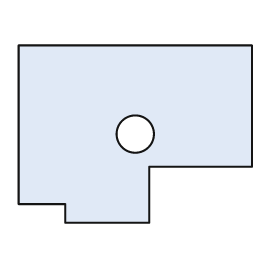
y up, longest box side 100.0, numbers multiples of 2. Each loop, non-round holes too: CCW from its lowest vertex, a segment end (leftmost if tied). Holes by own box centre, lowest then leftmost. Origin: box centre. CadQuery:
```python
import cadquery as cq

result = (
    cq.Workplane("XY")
    .moveTo(-30.0, -38.0)
    .lineTo(6.0, -38.0)
    .lineTo(6.0, -14.0)
    .lineTo(50.0, -14.0)
    .lineTo(50.0, 38.0)
    .lineTo(-50.0, 38.0)
    .lineTo(-50.0, -30.0)
    .lineTo(-30.0, -30.0)
    .close()
    .moveTo(0.0, 0.0)
    .circle(8.0)
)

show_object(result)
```